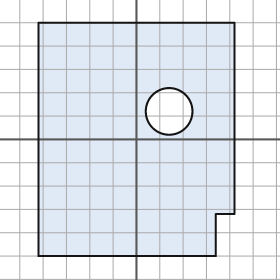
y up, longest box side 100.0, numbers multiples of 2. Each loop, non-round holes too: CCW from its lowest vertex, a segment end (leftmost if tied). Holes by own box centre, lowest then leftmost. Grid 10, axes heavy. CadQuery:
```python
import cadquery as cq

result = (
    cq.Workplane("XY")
    .moveTo(-42.0, -50.0)
    .lineTo(34.0, -50.0)
    .lineTo(34.0, -32.0)
    .lineTo(42.0, -32.0)
    .lineTo(42.0, 50.0)
    .lineTo(-42.0, 50.0)
    .close()
    .moveTo(14.0, 12.0)
    .circle(10.0)
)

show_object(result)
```